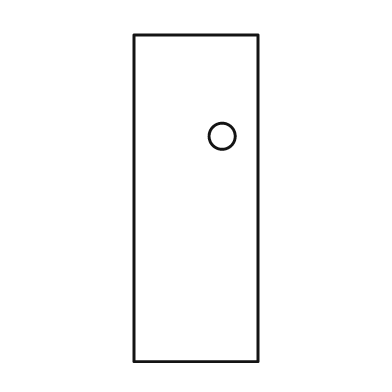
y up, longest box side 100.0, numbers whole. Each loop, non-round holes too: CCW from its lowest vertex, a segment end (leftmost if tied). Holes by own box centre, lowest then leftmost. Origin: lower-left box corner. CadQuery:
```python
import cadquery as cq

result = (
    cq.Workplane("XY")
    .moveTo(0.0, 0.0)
    .lineTo(38.0, 0.0)
    .lineTo(38.0, 100.0)
    .lineTo(0.0, 100.0)
    .close()
    .moveTo(27.0, 69.0)
    .circle(4.0)
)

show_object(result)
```